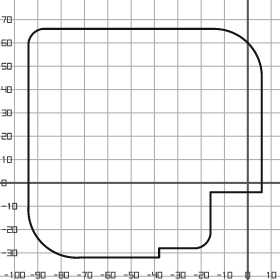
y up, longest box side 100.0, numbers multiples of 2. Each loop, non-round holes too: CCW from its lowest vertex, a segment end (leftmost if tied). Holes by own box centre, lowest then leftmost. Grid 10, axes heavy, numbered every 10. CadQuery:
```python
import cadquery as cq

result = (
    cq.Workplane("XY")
    .moveTo(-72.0, -32.0)
    .lineTo(-38.0, -32.0)
    .lineTo(-38.0, -28.0)
    .lineTo(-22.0, -28.0)
    .threePointArc((-18.0, -26.0), (-16.0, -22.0))
    .lineTo(-16.0, -4.0)
    .lineTo(6.0, -4.0)
    .lineTo(6.0, 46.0)
    .threePointArc((0.0, 60.0), (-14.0, 66.0))
    .lineTo(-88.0, 66.0)
    .threePointArc((-92.0, 64.0), (-94.0, 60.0))
    .lineTo(-94.0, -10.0)
    .threePointArc((-88.0, -26.0), (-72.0, -32.0))
    .close()
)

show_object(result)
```